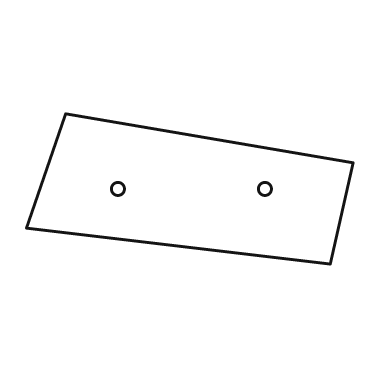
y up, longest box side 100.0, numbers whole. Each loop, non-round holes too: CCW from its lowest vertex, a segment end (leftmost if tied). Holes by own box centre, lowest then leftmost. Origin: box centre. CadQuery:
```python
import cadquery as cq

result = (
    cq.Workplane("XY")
    .moveTo(43.0, -23.0)
    .lineTo(50.0, 8.0)
    .lineTo(-38.0, 23.0)
    .lineTo(-50.0, -12.0)
    .close()
    .moveTo(-22.0, 0.0)
    .circle(2.0)
    .moveTo(23.0, 0.0)
    .circle(2.0)
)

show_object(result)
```